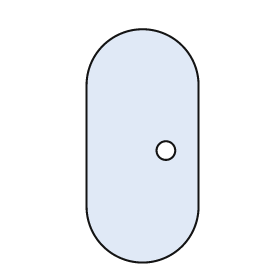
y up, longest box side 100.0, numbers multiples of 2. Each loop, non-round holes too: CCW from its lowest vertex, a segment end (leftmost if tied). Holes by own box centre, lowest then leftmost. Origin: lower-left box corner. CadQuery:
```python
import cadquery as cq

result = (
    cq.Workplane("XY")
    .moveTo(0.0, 24.0)
    .threePointArc((24.0, 0.0), (48.0, 24.0))
    .lineTo(48.0, 76.0)
    .threePointArc((24.0, 100.0), (0.0, 76.0))
    .close()
    .moveTo(34.0, 48.0)
    .circle(4.0)
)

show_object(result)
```